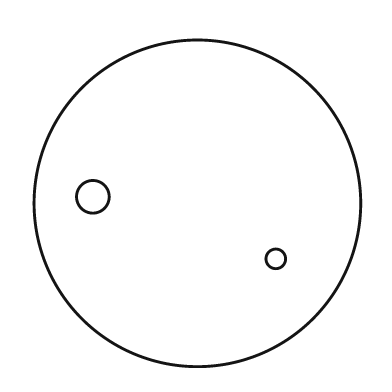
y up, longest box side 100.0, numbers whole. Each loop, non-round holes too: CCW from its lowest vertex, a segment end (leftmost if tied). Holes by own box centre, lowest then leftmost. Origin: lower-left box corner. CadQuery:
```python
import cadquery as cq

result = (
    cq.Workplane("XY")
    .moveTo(50.0, 50.0)
    .circle(50.0)
    .moveTo(74.0, 33.0)
    .circle(3.0)
    .moveTo(18.0, 52.0)
    .circle(5.0)
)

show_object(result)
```